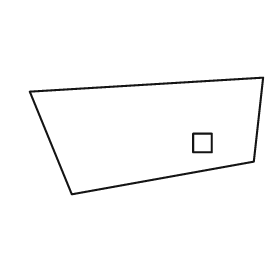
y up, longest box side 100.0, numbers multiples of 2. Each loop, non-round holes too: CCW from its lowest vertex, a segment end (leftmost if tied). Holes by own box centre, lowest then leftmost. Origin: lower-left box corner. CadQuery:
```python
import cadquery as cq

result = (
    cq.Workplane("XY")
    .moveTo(18.0, 0.0)
    .lineTo(96.0, 14.0)
    .lineTo(100.0, 50.0)
    .lineTo(0.0, 44.0)
    .close()
    .moveTo(70.0, 18.0)
    .lineTo(78.0, 18.0)
    .lineTo(78.0, 26.0)
    .lineTo(70.0, 26.0)
    .close()
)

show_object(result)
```